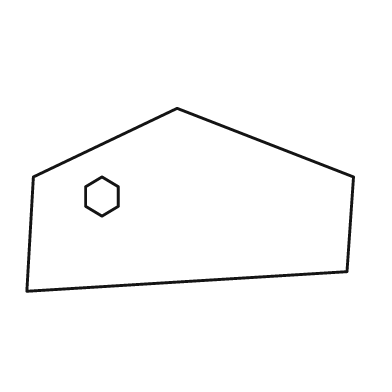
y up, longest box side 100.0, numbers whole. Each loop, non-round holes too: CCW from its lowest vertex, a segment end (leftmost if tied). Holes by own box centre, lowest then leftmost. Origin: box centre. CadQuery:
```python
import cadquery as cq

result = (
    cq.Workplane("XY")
    .moveTo(-50.0, -28.0)
    .lineTo(48.0, -22.0)
    .lineTo(50.0, 7.0)
    .lineTo(-4.0, 28.0)
    .lineTo(-48.0, 7.0)
    .close()
    .moveTo(-27.0, -5.0)
    .lineTo(-22.0, -2.0)
    .lineTo(-22.0, 4.0)
    .lineTo(-27.0, 7.0)
    .lineTo(-32.0, 4.0)
    .lineTo(-32.0, -2.0)
    .close()
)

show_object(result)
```